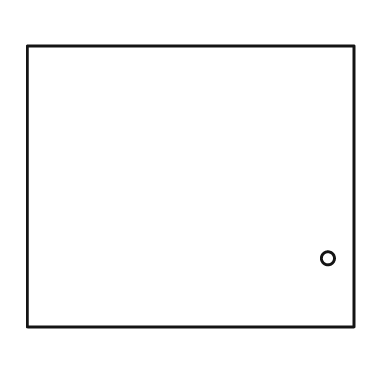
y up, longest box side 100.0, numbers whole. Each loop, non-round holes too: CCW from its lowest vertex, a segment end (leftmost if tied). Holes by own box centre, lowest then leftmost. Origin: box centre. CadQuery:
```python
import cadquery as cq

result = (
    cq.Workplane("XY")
    .moveTo(-50.0, -43.0)
    .lineTo(50.0, -43.0)
    .lineTo(50.0, 43.0)
    .lineTo(-50.0, 43.0)
    .close()
    .moveTo(42.0, -22.0)
    .circle(2.0)
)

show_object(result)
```